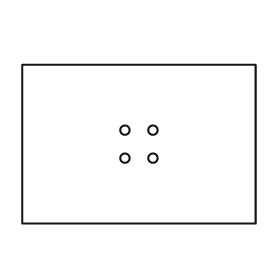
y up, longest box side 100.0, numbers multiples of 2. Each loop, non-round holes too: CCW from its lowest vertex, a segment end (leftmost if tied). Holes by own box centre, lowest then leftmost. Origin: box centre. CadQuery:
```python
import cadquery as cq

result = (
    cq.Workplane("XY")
    .moveTo(-50.0, -34.0)
    .lineTo(50.0, -34.0)
    .lineTo(50.0, 34.0)
    .lineTo(-50.0, 34.0)
    .close()
    .moveTo(-6.0, -6.0)
    .circle(2.0)
    .moveTo(6.0, -6.0)
    .circle(2.0)
    .moveTo(-6.0, 6.0)
    .circle(2.0)
    .moveTo(6.0, 6.0)
    .circle(2.0)
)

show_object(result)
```